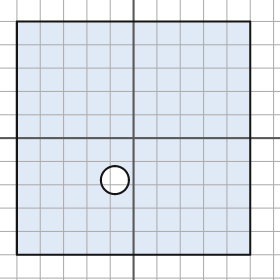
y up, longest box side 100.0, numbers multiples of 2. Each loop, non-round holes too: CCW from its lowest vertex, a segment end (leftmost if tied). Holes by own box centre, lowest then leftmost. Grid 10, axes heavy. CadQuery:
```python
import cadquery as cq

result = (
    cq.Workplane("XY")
    .moveTo(-50.0, -50.0)
    .lineTo(50.0, -50.0)
    .lineTo(50.0, 50.0)
    .lineTo(-50.0, 50.0)
    .close()
    .moveTo(-8.0, -18.0)
    .circle(6.0)
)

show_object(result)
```